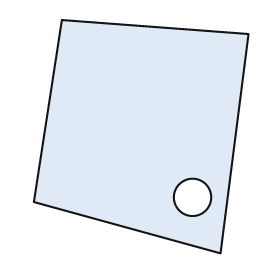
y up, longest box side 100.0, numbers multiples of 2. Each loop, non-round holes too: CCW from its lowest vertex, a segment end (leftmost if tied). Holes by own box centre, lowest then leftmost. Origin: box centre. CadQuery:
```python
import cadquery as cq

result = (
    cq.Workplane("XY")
    .moveTo(34.0, -50.0)
    .lineTo(46.0, 44.0)
    .lineTo(-34.0, 50.0)
    .lineTo(-46.0, -28.0)
    .close()
    .moveTo(22.0, -26.0)
    .circle(8.0)
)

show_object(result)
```